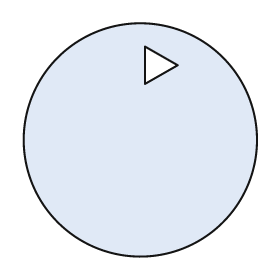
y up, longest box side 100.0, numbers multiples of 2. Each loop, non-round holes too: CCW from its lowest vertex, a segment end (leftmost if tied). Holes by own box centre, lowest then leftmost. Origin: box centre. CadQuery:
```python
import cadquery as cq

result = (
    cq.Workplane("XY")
    .moveTo(0.0, 0.0)
    .circle(50.0)
    .moveTo(2.0, 24.0)
    .lineTo(16.0, 32.0)
    .lineTo(2.0, 40.0)
    .close()
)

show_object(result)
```